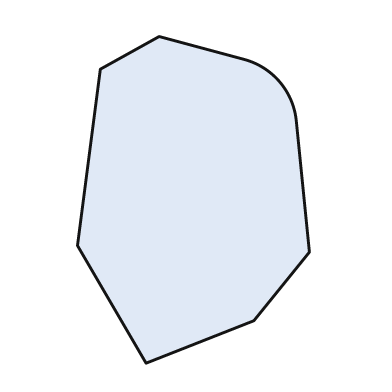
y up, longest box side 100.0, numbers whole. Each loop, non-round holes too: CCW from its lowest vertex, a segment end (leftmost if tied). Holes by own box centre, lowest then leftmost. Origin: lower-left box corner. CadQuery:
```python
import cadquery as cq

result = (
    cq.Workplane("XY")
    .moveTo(21.0, 0.0)
    .lineTo(54.0, 13.0)
    .lineTo(71.0, 34.0)
    .lineTo(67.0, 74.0)
    .threePointArc((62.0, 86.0), (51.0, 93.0))
    .lineTo(25.0, 100.0)
    .lineTo(7.0, 90.0)
    .lineTo(0.0, 36.0)
    .close()
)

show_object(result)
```